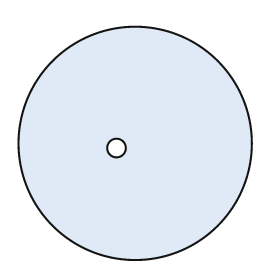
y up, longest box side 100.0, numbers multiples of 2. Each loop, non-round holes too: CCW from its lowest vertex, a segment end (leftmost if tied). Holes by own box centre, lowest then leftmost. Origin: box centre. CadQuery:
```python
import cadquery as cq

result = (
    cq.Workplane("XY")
    .moveTo(0.0, 0.0)
    .circle(50.0)
    .moveTo(-8.0, -2.0)
    .circle(4.0)
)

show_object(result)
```